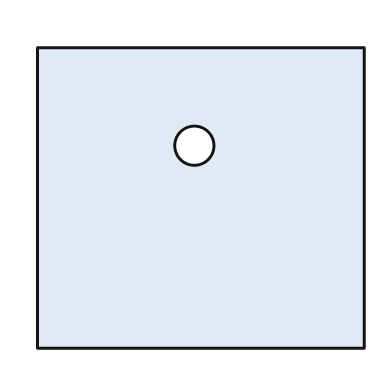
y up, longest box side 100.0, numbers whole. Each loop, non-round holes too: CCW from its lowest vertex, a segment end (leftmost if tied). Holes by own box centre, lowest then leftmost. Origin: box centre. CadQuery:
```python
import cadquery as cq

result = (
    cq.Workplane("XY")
    .moveTo(-50.0, -46.0)
    .lineTo(50.0, -46.0)
    .lineTo(50.0, 46.0)
    .lineTo(-50.0, 46.0)
    .close()
    .moveTo(-2.0, 16.0)
    .circle(6.0)
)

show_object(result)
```